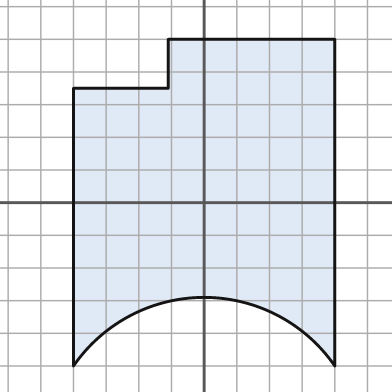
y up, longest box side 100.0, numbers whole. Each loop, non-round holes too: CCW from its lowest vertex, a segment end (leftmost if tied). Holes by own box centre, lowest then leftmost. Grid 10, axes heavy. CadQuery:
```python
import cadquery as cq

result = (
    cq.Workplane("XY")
    .moveTo(-40.0, -50.0)
    .threePointArc((0.0, -29.0), (40.0, -50.0))
    .lineTo(40.0, 50.0)
    .lineTo(-11.0, 50.0)
    .lineTo(-11.0, 35.0)
    .lineTo(-40.0, 35.0)
    .close()
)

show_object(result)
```